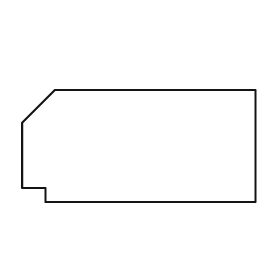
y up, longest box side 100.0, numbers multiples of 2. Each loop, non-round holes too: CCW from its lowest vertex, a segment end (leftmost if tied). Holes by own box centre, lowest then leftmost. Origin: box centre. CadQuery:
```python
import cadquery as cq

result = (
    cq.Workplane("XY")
    .moveTo(-40.0, -24.0)
    .lineTo(50.0, -24.0)
    .lineTo(50.0, 24.0)
    .lineTo(-36.0, 24.0)
    .lineTo(-50.0, 10.0)
    .lineTo(-50.0, -18.0)
    .lineTo(-40.0, -18.0)
    .close()
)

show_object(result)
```